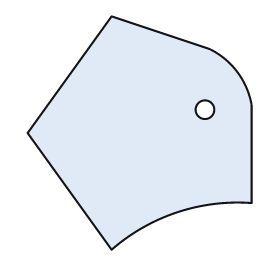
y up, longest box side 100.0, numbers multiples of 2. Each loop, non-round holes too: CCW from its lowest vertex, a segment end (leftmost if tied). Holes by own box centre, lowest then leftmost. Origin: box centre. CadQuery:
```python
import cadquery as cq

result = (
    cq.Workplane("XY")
    .moveTo(-12.0, -50.0)
    .threePointArc((16.0, -34.0), (48.0, -30.0))
    .lineTo(48.0, 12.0)
    .threePointArc((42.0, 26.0), (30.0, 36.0))
    .lineTo(-12.0, 50.0)
    .lineTo(-48.0, 0.0)
    .close()
    .moveTo(28.0, 10.0)
    .circle(4.0)
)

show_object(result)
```